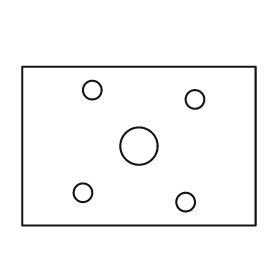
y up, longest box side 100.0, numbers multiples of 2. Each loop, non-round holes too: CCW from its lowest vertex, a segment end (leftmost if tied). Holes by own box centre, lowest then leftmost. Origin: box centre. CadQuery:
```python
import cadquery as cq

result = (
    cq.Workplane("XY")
    .moveTo(-50.0, -34.0)
    .lineTo(50.0, -34.0)
    .lineTo(50.0, 34.0)
    .lineTo(-50.0, 34.0)
    .close()
    .moveTo(20.0, -24.0)
    .circle(4.0)
    .moveTo(-24.0, -20.0)
    .circle(4.0)
    .moveTo(0.0, 0.0)
    .circle(8.0)
    .moveTo(24.0, 20.0)
    .circle(4.0)
    .moveTo(-20.0, 24.0)
    .circle(4.0)
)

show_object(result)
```